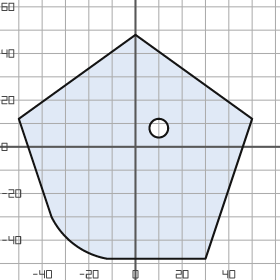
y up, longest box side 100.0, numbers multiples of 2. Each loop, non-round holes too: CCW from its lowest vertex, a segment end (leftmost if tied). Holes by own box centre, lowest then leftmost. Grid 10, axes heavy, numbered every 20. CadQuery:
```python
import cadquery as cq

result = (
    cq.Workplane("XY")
    .moveTo(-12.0, -48.0)
    .lineTo(30.0, -48.0)
    .lineTo(50.0, 12.0)
    .lineTo(0.0, 48.0)
    .lineTo(-50.0, 12.0)
    .lineTo(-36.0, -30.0)
    .threePointArc((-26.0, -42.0), (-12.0, -48.0))
    .close()
    .moveTo(10.0, 8.0)
    .circle(4.0)
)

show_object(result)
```